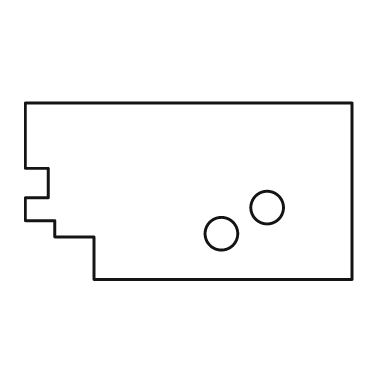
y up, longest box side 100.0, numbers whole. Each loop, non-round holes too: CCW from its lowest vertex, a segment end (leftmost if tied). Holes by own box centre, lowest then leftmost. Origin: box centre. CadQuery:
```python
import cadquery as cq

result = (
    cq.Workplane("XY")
    .moveTo(-29.0, -27.0)
    .lineTo(50.0, -27.0)
    .lineTo(50.0, 27.0)
    .lineTo(-50.0, 27.0)
    .lineTo(-50.0, 7.0)
    .lineTo(-43.0, 7.0)
    .lineTo(-43.0, -2.0)
    .lineTo(-50.0, -2.0)
    .lineTo(-50.0, -9.0)
    .lineTo(-41.0, -9.0)
    .lineTo(-41.0, -14.0)
    .lineTo(-29.0, -14.0)
    .close()
    .moveTo(10.0, -13.0)
    .circle(5.0)
    .moveTo(24.0, -5.0)
    .circle(5.0)
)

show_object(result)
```